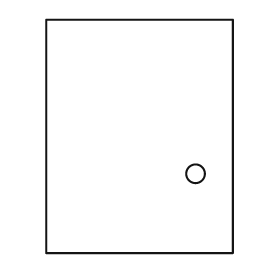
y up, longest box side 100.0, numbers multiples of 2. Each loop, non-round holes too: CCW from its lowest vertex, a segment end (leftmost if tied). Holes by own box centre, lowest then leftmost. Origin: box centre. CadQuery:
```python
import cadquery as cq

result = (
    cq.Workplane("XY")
    .moveTo(-40.0, -50.0)
    .lineTo(40.0, -50.0)
    .lineTo(40.0, 50.0)
    .lineTo(-40.0, 50.0)
    .close()
    .moveTo(24.0, -16.0)
    .circle(4.0)
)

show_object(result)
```